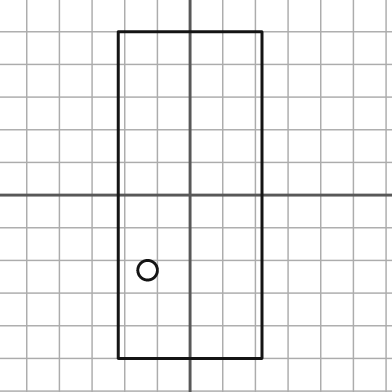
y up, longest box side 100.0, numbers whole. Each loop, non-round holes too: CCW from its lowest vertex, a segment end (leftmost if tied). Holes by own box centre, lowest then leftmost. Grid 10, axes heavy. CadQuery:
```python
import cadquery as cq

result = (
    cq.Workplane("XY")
    .moveTo(-22.0, -50.0)
    .lineTo(22.0, -50.0)
    .lineTo(22.0, 50.0)
    .lineTo(-22.0, 50.0)
    .close()
    .moveTo(-13.0, -23.0)
    .circle(3.0)
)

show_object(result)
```